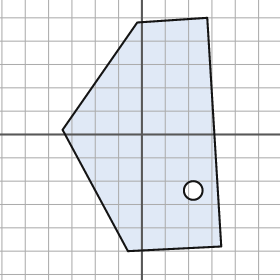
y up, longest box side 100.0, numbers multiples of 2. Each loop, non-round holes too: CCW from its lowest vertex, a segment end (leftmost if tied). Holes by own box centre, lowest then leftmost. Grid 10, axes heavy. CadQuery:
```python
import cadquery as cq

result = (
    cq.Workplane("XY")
    .moveTo(-6.0, -50.0)
    .lineTo(34.0, -48.0)
    .lineTo(28.0, 50.0)
    .lineTo(-2.0, 48.0)
    .lineTo(-34.0, 2.0)
    .close()
    .moveTo(22.0, -24.0)
    .circle(4.0)
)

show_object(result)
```